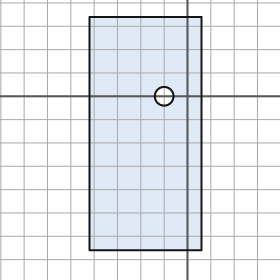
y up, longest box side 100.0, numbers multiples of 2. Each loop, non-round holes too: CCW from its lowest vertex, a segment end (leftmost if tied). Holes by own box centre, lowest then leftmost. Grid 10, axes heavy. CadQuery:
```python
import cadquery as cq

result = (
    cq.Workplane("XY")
    .moveTo(-42.0, -66.0)
    .lineTo(6.0, -66.0)
    .lineTo(6.0, 34.0)
    .lineTo(-42.0, 34.0)
    .close()
    .moveTo(-10.0, 0.0)
    .circle(4.0)
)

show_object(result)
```